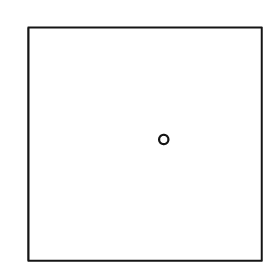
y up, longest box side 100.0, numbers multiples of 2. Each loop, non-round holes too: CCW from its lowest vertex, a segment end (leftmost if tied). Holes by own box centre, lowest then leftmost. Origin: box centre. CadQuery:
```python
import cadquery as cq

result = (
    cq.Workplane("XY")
    .moveTo(-50.0, -50.0)
    .lineTo(50.0, -50.0)
    .lineTo(50.0, 50.0)
    .lineTo(-50.0, 50.0)
    .close()
    .moveTo(8.0, 2.0)
    .circle(2.0)
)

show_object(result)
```